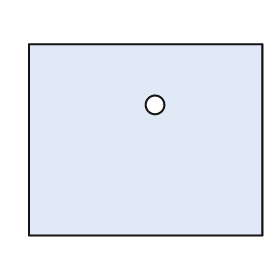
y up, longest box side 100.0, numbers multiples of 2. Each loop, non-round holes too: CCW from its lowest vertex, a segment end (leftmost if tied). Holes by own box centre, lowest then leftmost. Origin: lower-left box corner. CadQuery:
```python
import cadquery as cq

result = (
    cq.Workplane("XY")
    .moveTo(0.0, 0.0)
    .lineTo(100.0, 0.0)
    .lineTo(100.0, 82.0)
    .lineTo(0.0, 82.0)
    .close()
    .moveTo(54.0, 56.0)
    .circle(4.0)
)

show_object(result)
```